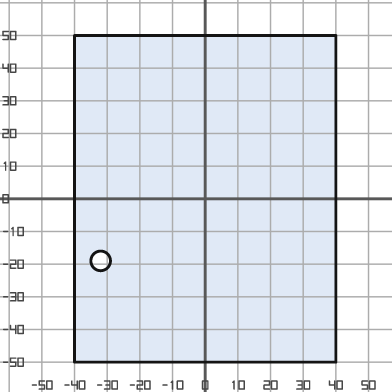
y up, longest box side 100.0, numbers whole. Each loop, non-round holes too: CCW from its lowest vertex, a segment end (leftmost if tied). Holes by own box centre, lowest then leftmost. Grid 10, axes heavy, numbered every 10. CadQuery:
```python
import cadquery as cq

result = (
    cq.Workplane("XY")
    .moveTo(-40.0, -50.0)
    .lineTo(40.0, -50.0)
    .lineTo(40.0, 50.0)
    .lineTo(-40.0, 50.0)
    .close()
    .moveTo(-32.0, -19.0)
    .circle(3.0)
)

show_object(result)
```